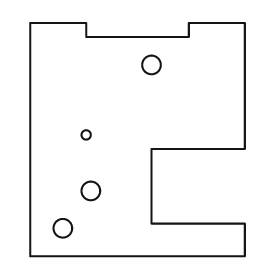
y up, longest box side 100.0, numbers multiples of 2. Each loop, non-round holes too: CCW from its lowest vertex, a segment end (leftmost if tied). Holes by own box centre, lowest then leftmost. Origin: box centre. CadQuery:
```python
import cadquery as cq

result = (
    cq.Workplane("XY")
    .moveTo(-46.0, -50.0)
    .lineTo(46.0, -50.0)
    .lineTo(46.0, -36.0)
    .lineTo(6.0, -36.0)
    .lineTo(6.0, -4.0)
    .lineTo(46.0, -4.0)
    .lineTo(46.0, 50.0)
    .lineTo(22.0, 50.0)
    .lineTo(22.0, 44.0)
    .lineTo(-22.0, 44.0)
    .lineTo(-22.0, 50.0)
    .lineTo(-46.0, 50.0)
    .close()
    .moveTo(-32.0, -38.0)
    .circle(4.0)
    .moveTo(-20.0, -22.0)
    .circle(4.0)
    .moveTo(-22.0, 2.0)
    .circle(2.0)
    .moveTo(6.0, 32.0)
    .circle(4.0)
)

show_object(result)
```